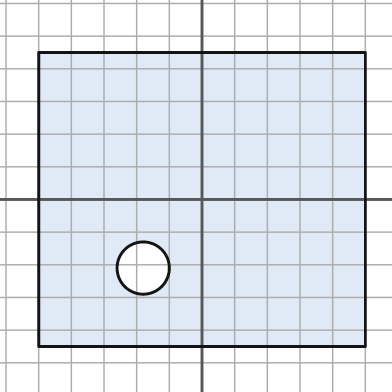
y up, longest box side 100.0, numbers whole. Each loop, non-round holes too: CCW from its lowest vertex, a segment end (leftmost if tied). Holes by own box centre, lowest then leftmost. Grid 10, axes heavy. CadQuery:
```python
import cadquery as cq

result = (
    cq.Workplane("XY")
    .moveTo(-50.0, -45.0)
    .lineTo(50.0, -45.0)
    .lineTo(50.0, 45.0)
    .lineTo(-50.0, 45.0)
    .close()
    .moveTo(-18.0, -21.0)
    .circle(8.0)
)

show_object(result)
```